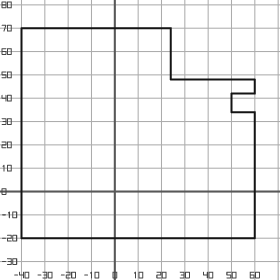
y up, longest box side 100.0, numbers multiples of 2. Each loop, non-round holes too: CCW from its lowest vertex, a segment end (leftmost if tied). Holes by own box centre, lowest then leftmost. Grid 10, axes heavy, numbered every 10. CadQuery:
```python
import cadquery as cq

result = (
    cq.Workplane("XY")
    .moveTo(-40.0, -20.0)
    .lineTo(60.0, -20.0)
    .lineTo(60.0, 34.0)
    .lineTo(50.0, 34.0)
    .lineTo(50.0, 42.0)
    .lineTo(60.0, 42.0)
    .lineTo(60.0, 48.0)
    .lineTo(24.0, 48.0)
    .lineTo(24.0, 70.0)
    .lineTo(-40.0, 70.0)
    .close()
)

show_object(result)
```